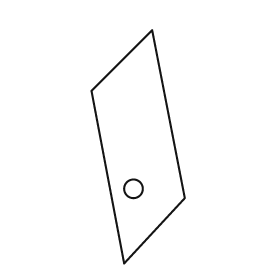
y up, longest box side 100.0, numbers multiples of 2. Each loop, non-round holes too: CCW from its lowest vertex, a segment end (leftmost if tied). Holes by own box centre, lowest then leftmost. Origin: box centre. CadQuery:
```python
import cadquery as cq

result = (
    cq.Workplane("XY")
    .moveTo(-6.0, -50.0)
    .lineTo(20.0, -22.0)
    .lineTo(6.0, 50.0)
    .lineTo(-20.0, 24.0)
    .close()
    .moveTo(-2.0, -18.0)
    .circle(4.0)
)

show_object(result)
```